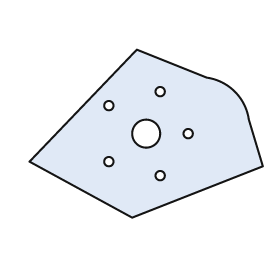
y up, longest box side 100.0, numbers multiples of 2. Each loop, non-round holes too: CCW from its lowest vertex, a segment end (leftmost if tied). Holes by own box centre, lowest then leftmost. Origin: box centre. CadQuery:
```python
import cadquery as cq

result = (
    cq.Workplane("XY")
    .moveTo(-6.0, -36.0)
    .lineTo(50.0, -14.0)
    .lineTo(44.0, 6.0)
    .threePointArc((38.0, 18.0), (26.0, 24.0))
    .lineTo(-4.0, 36.0)
    .lineTo(-50.0, -12.0)
    .close()
    .moveTo(6.0, -18.0)
    .circle(2.0)
    .moveTo(-16.0, -12.0)
    .circle(2.0)
    .moveTo(0.0, 0.0)
    .circle(6.0)
    .moveTo(18.0, 0.0)
    .circle(2.0)
    .moveTo(-16.0, 12.0)
    .circle(2.0)
    .moveTo(6.0, 18.0)
    .circle(2.0)
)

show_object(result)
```